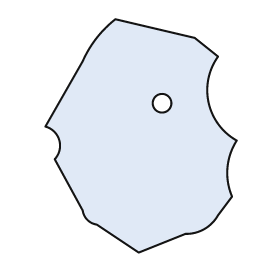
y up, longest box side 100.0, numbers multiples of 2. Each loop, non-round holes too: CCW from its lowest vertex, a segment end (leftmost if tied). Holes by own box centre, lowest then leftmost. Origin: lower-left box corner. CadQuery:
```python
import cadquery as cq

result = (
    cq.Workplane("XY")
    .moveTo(40.0, 0.0)
    .lineTo(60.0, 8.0)
    .threePointArc((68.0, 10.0), (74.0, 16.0))
    .lineTo(80.0, 24.0)
    .threePointArc((78.0, 36.0), (82.0, 48.0))
    .threePointArc((70.0, 64.0), (74.0, 84.0))
    .lineTo(64.0, 92.0)
    .lineTo(30.0, 100.0)
    .threePointArc((22.0, 92.0), (16.0, 82.0))
    .lineTo(0.0, 54.0)
    .threePointArc((6.0, 48.0), (4.0, 40.0))
    .lineTo(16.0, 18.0)
    .threePointArc((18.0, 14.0), (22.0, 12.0))
    .close()
    .moveTo(50.0, 64.0)
    .circle(4.0)
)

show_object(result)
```